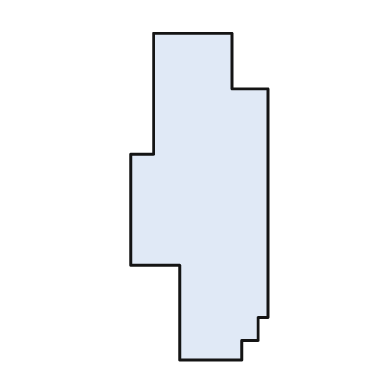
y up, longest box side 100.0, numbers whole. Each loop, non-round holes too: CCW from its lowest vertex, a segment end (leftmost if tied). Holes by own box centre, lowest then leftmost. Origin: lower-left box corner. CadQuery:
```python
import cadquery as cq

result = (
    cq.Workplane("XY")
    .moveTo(15.0, 0.0)
    .lineTo(34.0, 0.0)
    .lineTo(34.0, 6.0)
    .lineTo(39.0, 6.0)
    .lineTo(39.0, 13.0)
    .lineTo(42.0, 13.0)
    .lineTo(42.0, 83.0)
    .lineTo(31.0, 83.0)
    .lineTo(31.0, 100.0)
    .lineTo(7.0, 100.0)
    .lineTo(7.0, 63.0)
    .lineTo(0.0, 63.0)
    .lineTo(0.0, 29.0)
    .lineTo(15.0, 29.0)
    .close()
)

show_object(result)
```